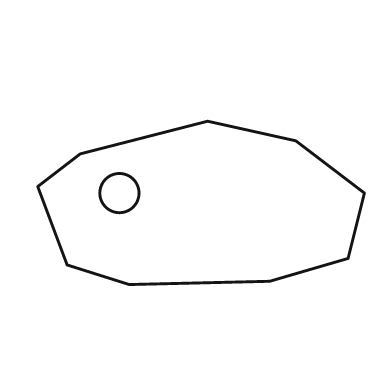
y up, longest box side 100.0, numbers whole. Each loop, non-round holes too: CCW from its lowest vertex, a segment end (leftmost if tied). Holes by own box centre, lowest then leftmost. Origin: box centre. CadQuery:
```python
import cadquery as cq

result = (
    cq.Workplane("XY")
    .moveTo(-22.0, -25.0)
    .lineTo(21.0, -24.0)
    .lineTo(45.0, -17.0)
    .lineTo(50.0, 3.0)
    .lineTo(29.0, 19.0)
    .lineTo(2.0, 25.0)
    .lineTo(-37.0, 15.0)
    .lineTo(-50.0, 5.0)
    .lineTo(-41.0, -19.0)
    .close()
    .moveTo(-25.0, 3.0)
    .circle(6.0)
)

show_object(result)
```